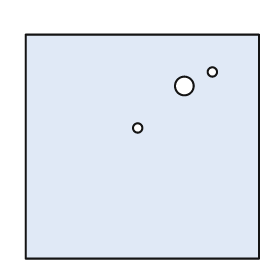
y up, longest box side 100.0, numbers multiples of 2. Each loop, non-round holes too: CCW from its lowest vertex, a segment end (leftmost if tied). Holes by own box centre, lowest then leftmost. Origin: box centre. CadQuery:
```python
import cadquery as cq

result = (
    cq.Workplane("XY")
    .moveTo(-50.0, -48.0)
    .lineTo(50.0, -48.0)
    .lineTo(50.0, 48.0)
    .lineTo(-50.0, 48.0)
    .close()
    .moveTo(-2.0, 8.0)
    .circle(2.0)
    .moveTo(18.0, 26.0)
    .circle(4.0)
    .moveTo(30.0, 32.0)
    .circle(2.0)
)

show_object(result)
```